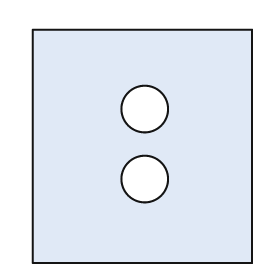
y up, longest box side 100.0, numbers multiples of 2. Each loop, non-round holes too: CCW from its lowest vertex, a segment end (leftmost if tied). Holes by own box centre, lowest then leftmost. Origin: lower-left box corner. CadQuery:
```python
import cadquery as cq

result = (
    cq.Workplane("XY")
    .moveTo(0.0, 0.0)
    .lineTo(94.0, 0.0)
    .lineTo(94.0, 100.0)
    .lineTo(0.0, 100.0)
    .close()
    .moveTo(48.0, 36.0)
    .circle(10.0)
    .moveTo(48.0, 66.0)
    .circle(10.0)
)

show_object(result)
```